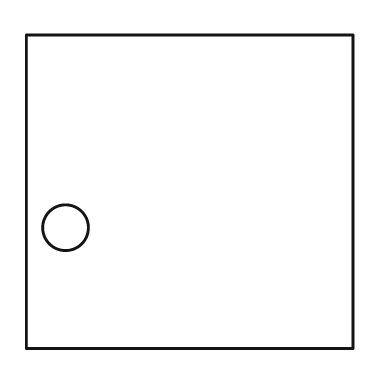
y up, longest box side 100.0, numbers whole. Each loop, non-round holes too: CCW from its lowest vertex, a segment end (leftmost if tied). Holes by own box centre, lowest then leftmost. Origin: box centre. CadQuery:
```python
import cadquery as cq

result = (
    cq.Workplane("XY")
    .moveTo(-50.0, -48.0)
    .lineTo(50.0, -48.0)
    .lineTo(50.0, 48.0)
    .lineTo(-50.0, 48.0)
    .close()
    .moveTo(-38.0, -11.0)
    .circle(7.0)
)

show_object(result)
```